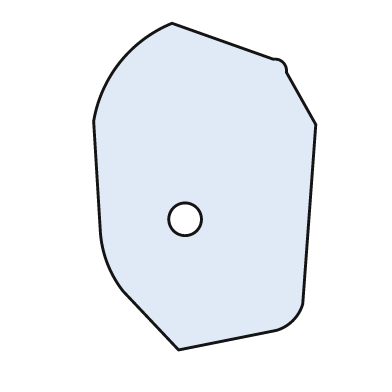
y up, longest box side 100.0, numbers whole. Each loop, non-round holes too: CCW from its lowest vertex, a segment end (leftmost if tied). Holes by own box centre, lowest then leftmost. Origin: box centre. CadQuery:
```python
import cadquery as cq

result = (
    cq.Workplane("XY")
    .moveTo(-8.0, -50.0)
    .lineTo(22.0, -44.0)
    .threePointArc((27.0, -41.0), (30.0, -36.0))
    .lineTo(34.0, 19.0)
    .lineTo(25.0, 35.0)
    .threePointArc((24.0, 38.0), (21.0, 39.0))
    .lineTo(-10.0, 50.0)
    .threePointArc((-26.0, 38.0), (-34.0, 20.0))
    .lineTo(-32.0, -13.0)
    .threePointArc((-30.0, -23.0), (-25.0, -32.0))
    .close()
    .moveTo(-6.0, -10.0)
    .circle(5.0)
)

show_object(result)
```